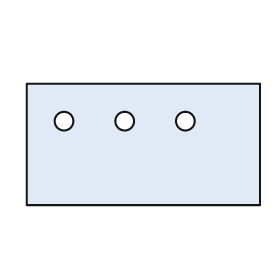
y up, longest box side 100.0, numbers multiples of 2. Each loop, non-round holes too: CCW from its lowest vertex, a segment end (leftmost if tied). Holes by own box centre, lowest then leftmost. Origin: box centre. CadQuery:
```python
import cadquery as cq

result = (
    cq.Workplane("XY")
    .moveTo(-50.0, -26.0)
    .lineTo(50.0, -26.0)
    .lineTo(50.0, 26.0)
    .lineTo(-50.0, 26.0)
    .close()
    .moveTo(-34.0, 10.0)
    .circle(4.0)
    .moveTo(-8.0, 10.0)
    .circle(4.0)
    .moveTo(18.0, 10.0)
    .circle(4.0)
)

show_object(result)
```